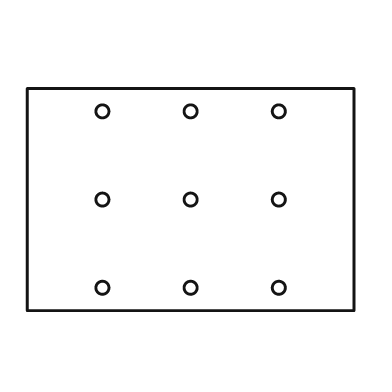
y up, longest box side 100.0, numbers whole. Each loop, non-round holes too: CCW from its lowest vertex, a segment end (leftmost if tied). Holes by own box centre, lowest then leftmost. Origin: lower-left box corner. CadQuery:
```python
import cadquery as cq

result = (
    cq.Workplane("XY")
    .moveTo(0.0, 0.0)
    .lineTo(100.0, 0.0)
    .lineTo(100.0, 68.0)
    .lineTo(0.0, 68.0)
    .close()
    .moveTo(23.0, 7.0)
    .circle(2.0)
    .moveTo(50.0, 7.0)
    .circle(2.0)
    .moveTo(77.0, 7.0)
    .circle(2.0)
    .moveTo(23.0, 34.0)
    .circle(2.0)
    .moveTo(50.0, 34.0)
    .circle(2.0)
    .moveTo(77.0, 34.0)
    .circle(2.0)
    .moveTo(23.0, 61.0)
    .circle(2.0)
    .moveTo(50.0, 61.0)
    .circle(2.0)
    .moveTo(77.0, 61.0)
    .circle(2.0)
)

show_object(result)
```